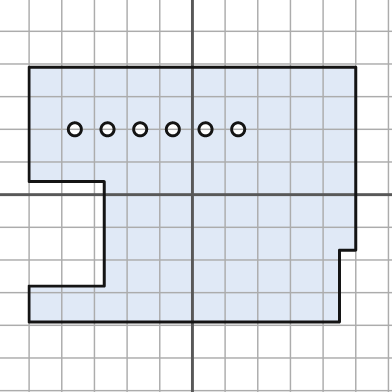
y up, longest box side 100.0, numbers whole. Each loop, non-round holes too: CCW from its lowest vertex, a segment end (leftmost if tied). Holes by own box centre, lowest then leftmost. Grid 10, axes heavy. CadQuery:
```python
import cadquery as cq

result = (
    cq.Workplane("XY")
    .moveTo(-50.0, -39.0)
    .lineTo(45.0, -39.0)
    .lineTo(45.0, -17.0)
    .lineTo(50.0, -17.0)
    .lineTo(50.0, 39.0)
    .lineTo(-50.0, 39.0)
    .lineTo(-50.0, 4.0)
    .lineTo(-27.0, 4.0)
    .lineTo(-27.0, -28.0)
    .lineTo(-50.0, -28.0)
    .close()
    .moveTo(-36.0, 20.0)
    .circle(2.0)
    .moveTo(-26.0, 20.0)
    .circle(2.0)
    .moveTo(-16.0, 20.0)
    .circle(2.0)
    .moveTo(-6.0, 20.0)
    .circle(2.0)
    .moveTo(4.0, 20.0)
    .circle(2.0)
    .moveTo(14.0, 20.0)
    .circle(2.0)
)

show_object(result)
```